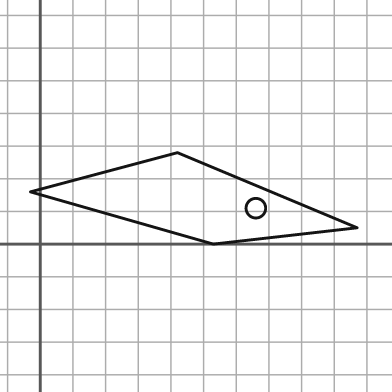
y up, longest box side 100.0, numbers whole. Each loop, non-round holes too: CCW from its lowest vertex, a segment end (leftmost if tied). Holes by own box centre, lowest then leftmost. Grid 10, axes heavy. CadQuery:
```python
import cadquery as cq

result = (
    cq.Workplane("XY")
    .moveTo(53.0, 0.0)
    .lineTo(97.0, 5.0)
    .lineTo(42.0, 28.0)
    .lineTo(-3.0, 16.0)
    .close()
    .moveTo(66.0, 11.0)
    .circle(3.0)
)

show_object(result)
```